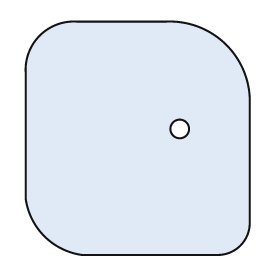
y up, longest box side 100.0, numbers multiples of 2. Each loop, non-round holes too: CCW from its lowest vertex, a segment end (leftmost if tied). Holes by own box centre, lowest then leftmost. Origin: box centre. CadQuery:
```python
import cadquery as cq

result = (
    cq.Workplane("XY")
    .moveTo(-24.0, -50.0)
    .lineTo(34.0, -50.0)
    .threePointArc((44.0, -46.0), (48.0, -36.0))
    .lineTo(48.0, 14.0)
    .threePointArc((38.0, 40.0), (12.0, 50.0))
    .lineTo(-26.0, 50.0)
    .threePointArc((-42.0, 44.0), (-48.0, 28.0))
    .lineTo(-48.0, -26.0)
    .threePointArc((-40.0, -42.0), (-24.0, -50.0))
    .close()
    .moveTo(18.0, 4.0)
    .circle(4.0)
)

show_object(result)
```